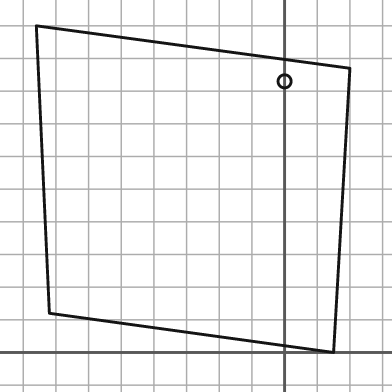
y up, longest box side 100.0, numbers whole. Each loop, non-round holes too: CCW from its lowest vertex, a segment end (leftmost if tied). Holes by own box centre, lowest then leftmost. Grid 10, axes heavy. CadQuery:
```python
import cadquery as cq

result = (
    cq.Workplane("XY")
    .moveTo(15.0, 0.0)
    .lineTo(20.0, 87.0)
    .lineTo(-76.0, 100.0)
    .lineTo(-72.0, 12.0)
    .close()
    .moveTo(0.0, 83.0)
    .circle(2.0)
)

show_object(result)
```